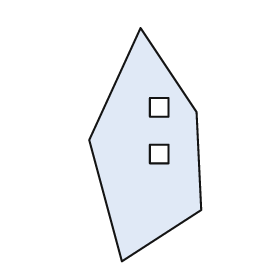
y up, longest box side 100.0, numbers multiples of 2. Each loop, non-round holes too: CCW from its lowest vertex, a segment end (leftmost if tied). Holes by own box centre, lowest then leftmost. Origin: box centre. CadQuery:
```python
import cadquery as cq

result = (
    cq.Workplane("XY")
    .moveTo(-10.0, -50.0)
    .lineTo(24.0, -28.0)
    .lineTo(22.0, 14.0)
    .lineTo(-2.0, 50.0)
    .lineTo(-24.0, 2.0)
    .close()
    .moveTo(2.0, -8.0)
    .lineTo(10.0, -8.0)
    .lineTo(10.0, 0.0)
    .lineTo(2.0, 0.0)
    .close()
    .moveTo(2.0, 12.0)
    .lineTo(10.0, 12.0)
    .lineTo(10.0, 20.0)
    .lineTo(2.0, 20.0)
    .close()
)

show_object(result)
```